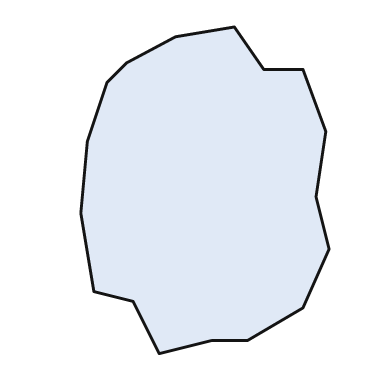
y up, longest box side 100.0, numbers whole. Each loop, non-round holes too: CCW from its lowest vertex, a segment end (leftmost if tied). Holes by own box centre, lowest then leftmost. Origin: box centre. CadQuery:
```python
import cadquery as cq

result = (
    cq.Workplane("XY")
    .moveTo(-14.0, -50.0)
    .lineTo(2.0, -46.0)
    .lineTo(13.0, -46.0)
    .lineTo(30.0, -36.0)
    .lineTo(38.0, -18.0)
    .lineTo(34.0, -2.0)
    .lineTo(37.0, 18.0)
    .lineTo(30.0, 37.0)
    .lineTo(18.0, 37.0)
    .lineTo(9.0, 50.0)
    .lineTo(-9.0, 47.0)
    .lineTo(-24.0, 39.0)
    .lineTo(-30.0, 33.0)
    .lineTo(-36.0, 15.0)
    .lineTo(-38.0, -7.0)
    .lineTo(-34.0, -31.0)
    .lineTo(-22.0, -34.0)
    .close()
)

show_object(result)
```